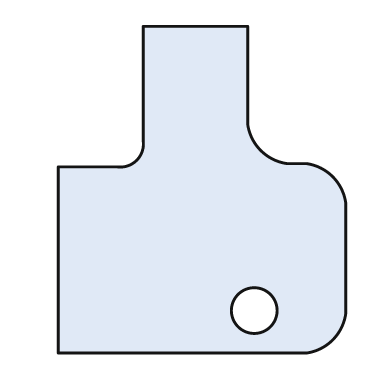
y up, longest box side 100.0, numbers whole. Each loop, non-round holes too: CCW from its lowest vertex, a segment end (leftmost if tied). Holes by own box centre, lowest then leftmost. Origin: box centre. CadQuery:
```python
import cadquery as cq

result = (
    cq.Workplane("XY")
    .moveTo(-44.0, -50.0)
    .lineTo(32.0, -50.0)
    .threePointArc((40.0, -46.0), (44.0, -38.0))
    .lineTo(44.0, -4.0)
    .threePointArc((40.0, 4.0), (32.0, 8.0))
    .lineTo(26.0, 8.0)
    .threePointArc((18.0, 12.0), (14.0, 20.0))
    .lineTo(14.0, 50.0)
    .lineTo(-18.0, 50.0)
    .lineTo(-18.0, 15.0)
    .threePointArc((-20.0, 9.0), (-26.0, 7.0))
    .lineTo(-44.0, 7.0)
    .close()
    .moveTo(16.0, -37.0)
    .circle(7.0)
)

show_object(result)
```